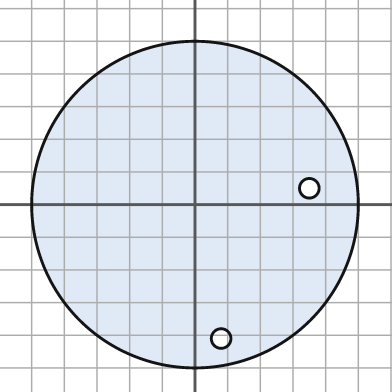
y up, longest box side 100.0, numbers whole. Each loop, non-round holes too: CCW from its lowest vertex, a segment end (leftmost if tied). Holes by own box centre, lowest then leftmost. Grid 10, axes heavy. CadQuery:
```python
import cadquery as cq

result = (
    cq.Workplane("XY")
    .moveTo(0.0, 0.0)
    .circle(50.0)
    .moveTo(8.0, -41.0)
    .circle(3.0)
    .moveTo(35.0, 5.0)
    .circle(3.0)
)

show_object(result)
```